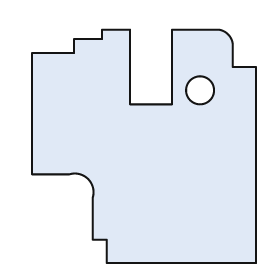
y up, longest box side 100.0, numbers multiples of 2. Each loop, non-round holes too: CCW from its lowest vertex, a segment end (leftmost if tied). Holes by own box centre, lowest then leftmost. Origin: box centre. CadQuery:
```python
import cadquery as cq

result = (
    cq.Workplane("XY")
    .moveTo(-16.0, -50.0)
    .lineTo(48.0, -50.0)
    .lineTo(48.0, 34.0)
    .lineTo(38.0, 34.0)
    .lineTo(38.0, 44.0)
    .threePointArc((36.0, 48.0), (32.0, 50.0))
    .lineTo(12.0, 50.0)
    .lineTo(12.0, 18.0)
    .lineTo(-6.0, 18.0)
    .lineTo(-6.0, 50.0)
    .lineTo(-18.0, 50.0)
    .lineTo(-18.0, 46.0)
    .lineTo(-30.0, 46.0)
    .lineTo(-30.0, 40.0)
    .lineTo(-48.0, 40.0)
    .lineTo(-48.0, -12.0)
    .lineTo(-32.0, -12.0)
    .threePointArc((-24.0, -14.0), (-22.0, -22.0))
    .lineTo(-22.0, -40.0)
    .lineTo(-16.0, -40.0)
    .close()
    .moveTo(24.0, 24.0)
    .circle(6.0)
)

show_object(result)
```